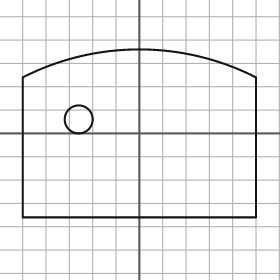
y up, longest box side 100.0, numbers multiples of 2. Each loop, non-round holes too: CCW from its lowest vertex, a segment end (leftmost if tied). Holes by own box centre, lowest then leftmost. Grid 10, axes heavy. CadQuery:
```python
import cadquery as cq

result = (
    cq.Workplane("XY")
    .moveTo(-50.0, -36.0)
    .lineTo(50.0, -36.0)
    .lineTo(50.0, 24.0)
    .threePointArc((0.0, 36.0), (-50.0, 24.0))
    .close()
    .moveTo(-26.0, 6.0)
    .circle(6.0)
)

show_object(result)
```